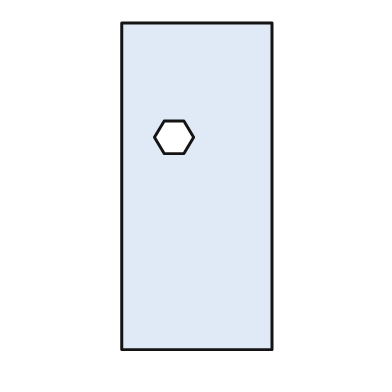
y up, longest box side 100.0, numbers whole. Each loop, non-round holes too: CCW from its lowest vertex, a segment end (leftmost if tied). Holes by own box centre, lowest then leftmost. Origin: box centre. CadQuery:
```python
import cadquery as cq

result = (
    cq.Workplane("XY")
    .moveTo(-23.0, -50.0)
    .lineTo(23.0, -50.0)
    .lineTo(23.0, 50.0)
    .lineTo(-23.0, 50.0)
    .close()
    .moveTo(-10.0, 10.0)
    .lineTo(-4.0, 10.0)
    .lineTo(-1.0, 15.0)
    .lineTo(-4.0, 20.0)
    .lineTo(-10.0, 20.0)
    .lineTo(-13.0, 15.0)
    .close()
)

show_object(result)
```